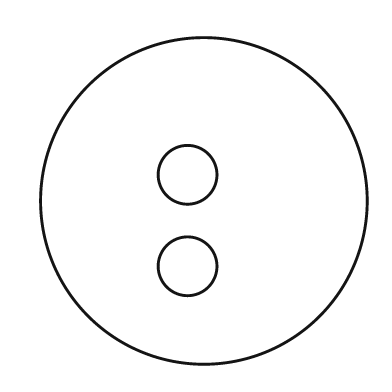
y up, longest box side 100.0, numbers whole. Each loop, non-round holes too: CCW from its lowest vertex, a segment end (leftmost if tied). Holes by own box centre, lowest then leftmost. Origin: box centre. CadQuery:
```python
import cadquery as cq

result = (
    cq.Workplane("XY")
    .moveTo(0.0, 0.0)
    .circle(50.0)
    .moveTo(-5.0, -20.0)
    .circle(9.0)
    .moveTo(-5.0, 8.0)
    .circle(9.0)
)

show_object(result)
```